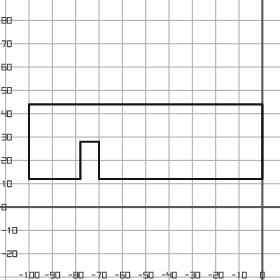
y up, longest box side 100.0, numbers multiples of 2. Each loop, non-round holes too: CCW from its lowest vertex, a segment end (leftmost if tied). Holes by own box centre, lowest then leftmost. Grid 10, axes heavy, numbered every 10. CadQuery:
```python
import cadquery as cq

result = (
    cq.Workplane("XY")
    .moveTo(-100.0, 12.0)
    .lineTo(-78.0, 12.0)
    .lineTo(-78.0, 28.0)
    .lineTo(-70.0, 28.0)
    .lineTo(-70.0, 12.0)
    .lineTo(0.0, 12.0)
    .lineTo(0.0, 44.0)
    .lineTo(-100.0, 44.0)
    .close()
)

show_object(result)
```